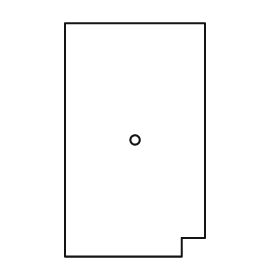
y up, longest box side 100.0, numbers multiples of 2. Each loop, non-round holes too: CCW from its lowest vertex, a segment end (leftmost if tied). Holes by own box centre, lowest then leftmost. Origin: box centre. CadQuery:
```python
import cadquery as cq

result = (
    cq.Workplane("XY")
    .moveTo(-30.0, -50.0)
    .lineTo(20.0, -50.0)
    .lineTo(20.0, -42.0)
    .lineTo(30.0, -42.0)
    .lineTo(30.0, 50.0)
    .lineTo(-30.0, 50.0)
    .close()
    .moveTo(0.0, 0.0)
    .circle(2.0)
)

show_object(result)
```